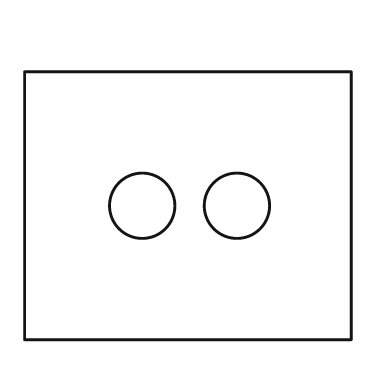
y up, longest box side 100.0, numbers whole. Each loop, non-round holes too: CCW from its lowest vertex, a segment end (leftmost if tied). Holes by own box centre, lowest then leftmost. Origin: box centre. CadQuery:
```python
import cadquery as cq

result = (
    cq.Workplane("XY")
    .moveTo(-50.0, -41.0)
    .lineTo(50.0, -41.0)
    .lineTo(50.0, 41.0)
    .lineTo(-50.0, 41.0)
    .close()
    .moveTo(-14.0, 0.0)
    .circle(10.0)
    .moveTo(15.0, 0.0)
    .circle(10.0)
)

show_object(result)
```